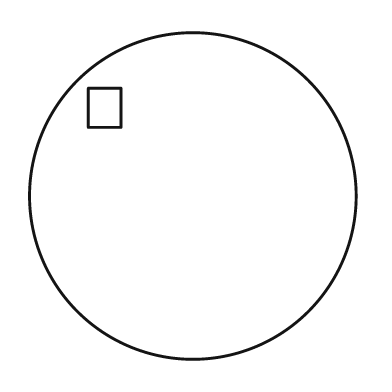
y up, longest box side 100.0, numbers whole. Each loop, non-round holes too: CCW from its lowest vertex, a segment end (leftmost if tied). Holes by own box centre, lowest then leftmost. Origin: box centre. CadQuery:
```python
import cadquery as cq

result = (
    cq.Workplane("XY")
    .moveTo(0.0, 0.0)
    .circle(50.0)
    .moveTo(-32.0, 21.0)
    .lineTo(-22.0, 21.0)
    .lineTo(-22.0, 33.0)
    .lineTo(-32.0, 33.0)
    .close()
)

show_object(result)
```